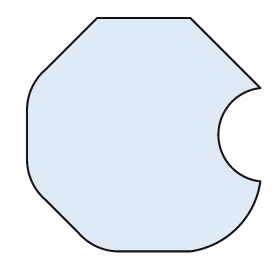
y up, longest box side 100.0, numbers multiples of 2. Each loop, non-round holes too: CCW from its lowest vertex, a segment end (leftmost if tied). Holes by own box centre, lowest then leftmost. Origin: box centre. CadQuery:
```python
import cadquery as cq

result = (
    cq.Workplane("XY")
    .moveTo(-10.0, -50.0)
    .lineTo(20.0, -50.0)
    .threePointArc((40.0, -40.0), (50.0, -20.0))
    .threePointArc((32.0, 0.0), (50.0, 20.0))
    .lineTo(20.0, 50.0)
    .lineTo(-20.0, 50.0)
    .lineTo(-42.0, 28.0)
    .threePointArc((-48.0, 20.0), (-50.0, 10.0))
    .lineTo(-50.0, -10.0)
    .threePointArc((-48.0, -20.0), (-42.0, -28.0))
    .lineTo(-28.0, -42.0)
    .threePointArc((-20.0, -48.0), (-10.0, -50.0))
    .close()
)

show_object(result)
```